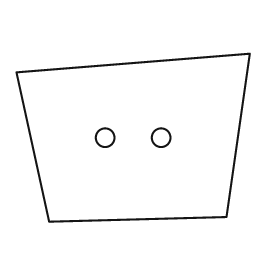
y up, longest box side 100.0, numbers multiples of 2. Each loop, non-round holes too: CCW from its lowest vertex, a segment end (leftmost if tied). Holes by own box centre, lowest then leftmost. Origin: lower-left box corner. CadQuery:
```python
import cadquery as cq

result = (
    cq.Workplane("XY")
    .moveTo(14.0, 0.0)
    .lineTo(90.0, 2.0)
    .lineTo(100.0, 72.0)
    .lineTo(0.0, 64.0)
    .close()
    .moveTo(38.0, 36.0)
    .circle(4.0)
    .moveTo(62.0, 36.0)
    .circle(4.0)
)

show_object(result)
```